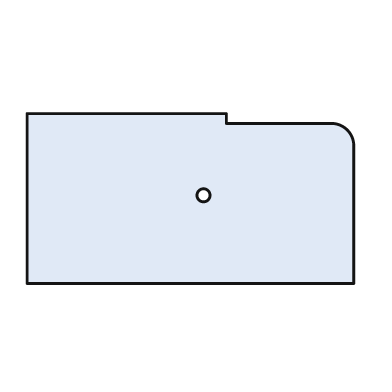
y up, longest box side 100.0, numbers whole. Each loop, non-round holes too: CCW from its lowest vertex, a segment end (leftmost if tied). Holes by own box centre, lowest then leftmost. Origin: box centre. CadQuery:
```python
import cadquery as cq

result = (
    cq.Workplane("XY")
    .moveTo(-50.0, -26.0)
    .lineTo(50.0, -26.0)
    .lineTo(50.0, 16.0)
    .threePointArc((48.0, 21.0), (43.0, 23.0))
    .lineTo(11.0, 23.0)
    .lineTo(11.0, 26.0)
    .lineTo(-50.0, 26.0)
    .close()
    .moveTo(4.0, 1.0)
    .circle(2.0)
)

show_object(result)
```